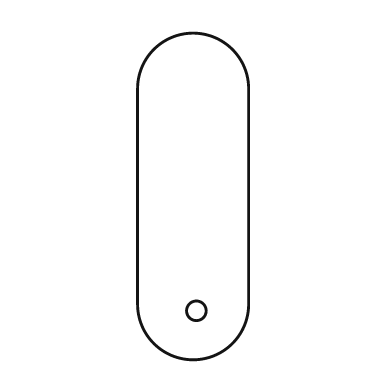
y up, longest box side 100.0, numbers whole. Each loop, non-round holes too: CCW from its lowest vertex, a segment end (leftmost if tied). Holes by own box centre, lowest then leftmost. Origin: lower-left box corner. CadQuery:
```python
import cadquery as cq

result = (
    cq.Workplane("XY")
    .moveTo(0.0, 17.0)
    .threePointArc((17.0, 0.0), (34.0, 17.0))
    .lineTo(34.0, 83.0)
    .threePointArc((17.0, 100.0), (0.0, 83.0))
    .close()
    .moveTo(18.0, 15.0)
    .circle(3.0)
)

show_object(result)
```